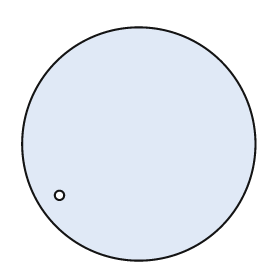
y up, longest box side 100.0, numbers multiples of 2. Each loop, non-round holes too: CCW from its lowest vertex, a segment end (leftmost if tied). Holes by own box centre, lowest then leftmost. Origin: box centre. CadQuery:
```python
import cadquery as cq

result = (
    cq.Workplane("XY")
    .moveTo(0.0, 0.0)
    .circle(50.0)
    .moveTo(-34.0, -22.0)
    .circle(2.0)
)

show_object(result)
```